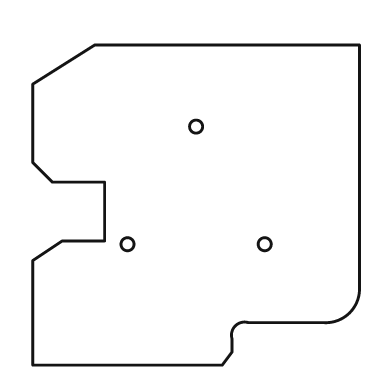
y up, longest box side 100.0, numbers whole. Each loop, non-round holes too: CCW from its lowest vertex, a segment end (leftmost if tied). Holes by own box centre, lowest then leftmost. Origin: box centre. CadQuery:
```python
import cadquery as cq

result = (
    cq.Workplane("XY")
    .moveTo(-50.0, -49.0)
    .lineTo(8.0, -49.0)
    .lineTo(11.0, -45.0)
    .lineTo(11.0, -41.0)
    .threePointArc((12.0, -37.0), (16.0, -36.0))
    .lineTo(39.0, -36.0)
    .threePointArc((47.0, -33.0), (50.0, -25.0))
    .lineTo(50.0, 49.0)
    .lineTo(-31.0, 49.0)
    .lineTo(-50.0, 37.0)
    .lineTo(-50.0, 13.0)
    .lineTo(-44.0, 7.0)
    .lineTo(-28.0, 7.0)
    .lineTo(-28.0, -11.0)
    .lineTo(-41.0, -11.0)
    .lineTo(-50.0, -17.0)
    .close()
    .moveTo(-21.0, -12.0)
    .circle(2.0)
    .moveTo(21.0, -12.0)
    .circle(2.0)
    .moveTo(0.0, 24.0)
    .circle(2.0)
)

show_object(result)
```